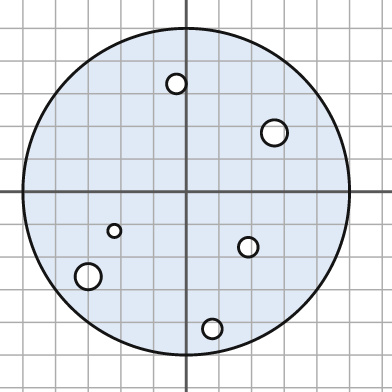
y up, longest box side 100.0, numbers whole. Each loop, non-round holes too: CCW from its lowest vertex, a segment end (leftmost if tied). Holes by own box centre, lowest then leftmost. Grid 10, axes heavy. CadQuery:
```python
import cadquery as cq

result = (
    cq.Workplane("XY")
    .moveTo(0.0, 0.0)
    .circle(50.0)
    .moveTo(8.0, -42.0)
    .circle(3.0)
    .moveTo(-30.0, -26.0)
    .circle(4.0)
    .moveTo(19.0, -17.0)
    .circle(3.0)
    .moveTo(-22.0, -12.0)
    .circle(2.0)
    .moveTo(27.0, 18.0)
    .circle(4.0)
    .moveTo(-3.0, 33.0)
    .circle(3.0)
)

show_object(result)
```